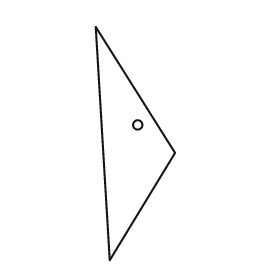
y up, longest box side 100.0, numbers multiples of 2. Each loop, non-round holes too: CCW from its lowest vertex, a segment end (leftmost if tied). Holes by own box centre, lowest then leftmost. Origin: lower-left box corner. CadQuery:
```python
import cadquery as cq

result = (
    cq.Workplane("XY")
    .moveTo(6.0, 0.0)
    .lineTo(34.0, 46.0)
    .lineTo(0.0, 100.0)
    .close()
    .moveTo(18.0, 58.0)
    .circle(2.0)
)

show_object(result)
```